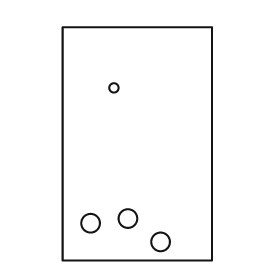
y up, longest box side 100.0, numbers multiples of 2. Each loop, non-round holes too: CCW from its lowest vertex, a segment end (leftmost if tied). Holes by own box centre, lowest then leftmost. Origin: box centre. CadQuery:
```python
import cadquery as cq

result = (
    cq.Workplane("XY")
    .moveTo(-32.0, -50.0)
    .lineTo(32.0, -50.0)
    .lineTo(32.0, 50.0)
    .lineTo(-32.0, 50.0)
    .close()
    .moveTo(10.0, -42.0)
    .circle(4.0)
    .moveTo(-20.0, -34.0)
    .circle(4.0)
    .moveTo(-4.0, -32.0)
    .circle(4.0)
    .moveTo(-10.0, 24.0)
    .circle(2.0)
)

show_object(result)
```